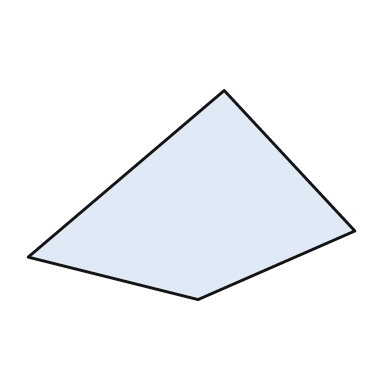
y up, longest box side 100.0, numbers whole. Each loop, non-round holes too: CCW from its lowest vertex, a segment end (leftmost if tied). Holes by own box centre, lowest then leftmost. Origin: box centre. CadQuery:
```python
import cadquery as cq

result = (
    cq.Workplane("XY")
    .moveTo(2.0, -32.0)
    .lineTo(50.0, -11.0)
    .lineTo(10.0, 32.0)
    .lineTo(-50.0, -19.0)
    .close()
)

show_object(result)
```